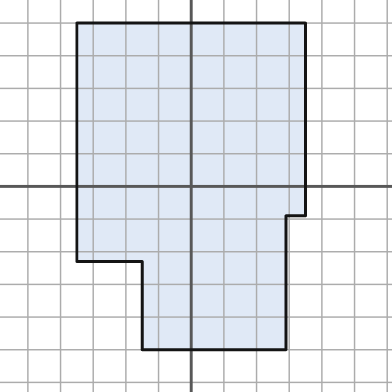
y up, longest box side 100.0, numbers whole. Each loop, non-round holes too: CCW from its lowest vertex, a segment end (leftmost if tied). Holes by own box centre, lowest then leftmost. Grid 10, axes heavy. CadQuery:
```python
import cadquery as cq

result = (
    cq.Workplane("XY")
    .moveTo(-15.0, -50.0)
    .lineTo(29.0, -50.0)
    .lineTo(29.0, -9.0)
    .lineTo(35.0, -9.0)
    .lineTo(35.0, 50.0)
    .lineTo(-35.0, 50.0)
    .lineTo(-35.0, -23.0)
    .lineTo(-15.0, -23.0)
    .close()
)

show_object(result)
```